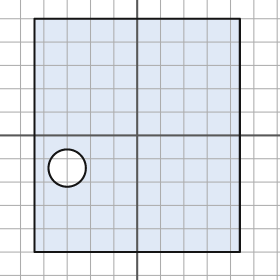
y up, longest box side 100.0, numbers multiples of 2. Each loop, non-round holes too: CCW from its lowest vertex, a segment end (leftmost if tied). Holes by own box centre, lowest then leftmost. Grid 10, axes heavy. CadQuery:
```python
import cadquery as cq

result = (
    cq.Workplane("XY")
    .moveTo(-44.0, -50.0)
    .lineTo(44.0, -50.0)
    .lineTo(44.0, 50.0)
    .lineTo(-44.0, 50.0)
    .close()
    .moveTo(-30.0, -14.0)
    .circle(8.0)
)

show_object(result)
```